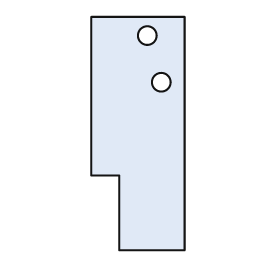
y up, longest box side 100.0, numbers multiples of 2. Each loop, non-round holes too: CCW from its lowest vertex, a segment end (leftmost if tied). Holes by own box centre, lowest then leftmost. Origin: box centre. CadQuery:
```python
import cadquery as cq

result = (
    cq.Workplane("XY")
    .moveTo(-8.0, -50.0)
    .lineTo(20.0, -50.0)
    .lineTo(20.0, 50.0)
    .lineTo(-20.0, 50.0)
    .lineTo(-20.0, -18.0)
    .lineTo(-8.0, -18.0)
    .close()
    .moveTo(10.0, 22.0)
    .circle(4.0)
    .moveTo(4.0, 42.0)
    .circle(4.0)
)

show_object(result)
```